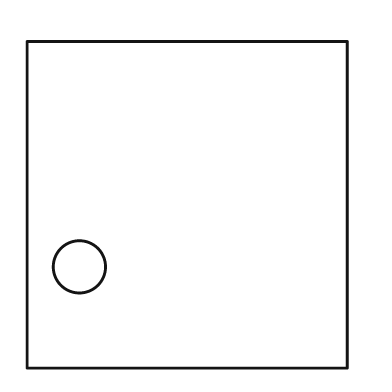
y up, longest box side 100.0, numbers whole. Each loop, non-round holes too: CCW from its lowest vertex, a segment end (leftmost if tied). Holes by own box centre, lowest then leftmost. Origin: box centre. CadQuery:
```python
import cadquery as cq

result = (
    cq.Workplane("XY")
    .moveTo(-49.0, -50.0)
    .lineTo(49.0, -50.0)
    .lineTo(49.0, 50.0)
    .lineTo(-49.0, 50.0)
    .close()
    .moveTo(-33.0, -19.0)
    .circle(8.0)
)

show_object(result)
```